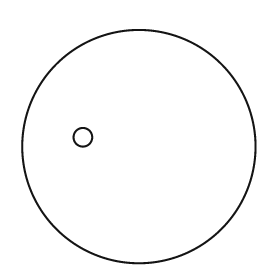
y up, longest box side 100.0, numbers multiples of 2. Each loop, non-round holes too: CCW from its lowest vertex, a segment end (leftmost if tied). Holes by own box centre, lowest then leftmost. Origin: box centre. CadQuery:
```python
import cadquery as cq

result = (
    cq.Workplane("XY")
    .moveTo(0.0, 0.0)
    .circle(50.0)
    .moveTo(-24.0, 4.0)
    .circle(4.0)
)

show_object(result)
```